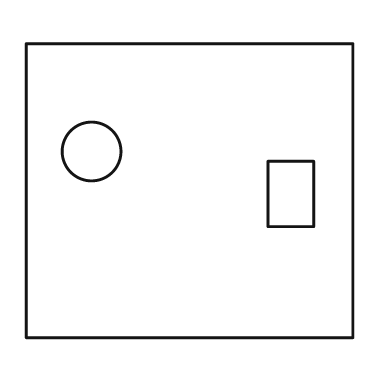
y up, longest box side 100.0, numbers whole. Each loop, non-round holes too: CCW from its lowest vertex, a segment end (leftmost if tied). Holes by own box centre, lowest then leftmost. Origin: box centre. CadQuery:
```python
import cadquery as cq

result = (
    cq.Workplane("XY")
    .moveTo(-50.0, -45.0)
    .lineTo(50.0, -45.0)
    .lineTo(50.0, 45.0)
    .lineTo(-50.0, 45.0)
    .close()
    .moveTo(24.0, -11.0)
    .lineTo(38.0, -11.0)
    .lineTo(38.0, 9.0)
    .lineTo(24.0, 9.0)
    .close()
    .moveTo(-30.0, 12.0)
    .circle(9.0)
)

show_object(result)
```